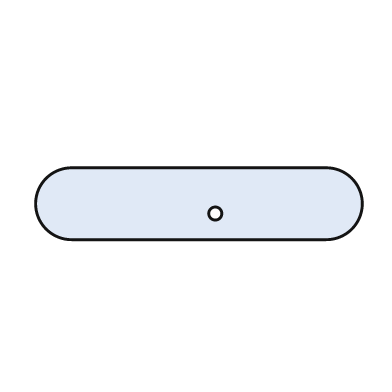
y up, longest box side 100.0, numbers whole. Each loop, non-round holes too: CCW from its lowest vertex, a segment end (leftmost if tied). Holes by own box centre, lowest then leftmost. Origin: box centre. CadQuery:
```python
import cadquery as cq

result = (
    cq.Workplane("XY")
    .moveTo(-39.0, -11.0)
    .lineTo(39.0, -11.0)
    .threePointArc((50.0, 0.0), (39.0, 11.0))
    .lineTo(-39.0, 11.0)
    .threePointArc((-50.0, 0.0), (-39.0, -11.0))
    .close()
    .moveTo(5.0, -3.0)
    .circle(2.0)
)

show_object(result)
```